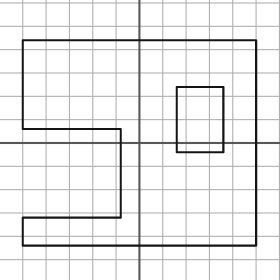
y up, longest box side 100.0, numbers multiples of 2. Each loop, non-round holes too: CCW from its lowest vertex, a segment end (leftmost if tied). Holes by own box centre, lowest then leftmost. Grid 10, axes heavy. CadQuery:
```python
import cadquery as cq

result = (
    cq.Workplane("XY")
    .moveTo(-50.0, -44.0)
    .lineTo(50.0, -44.0)
    .lineTo(50.0, 44.0)
    .lineTo(-50.0, 44.0)
    .lineTo(-50.0, 6.0)
    .lineTo(-8.0, 6.0)
    .lineTo(-8.0, -32.0)
    .lineTo(-50.0, -32.0)
    .close()
    .moveTo(16.0, -4.0)
    .lineTo(36.0, -4.0)
    .lineTo(36.0, 24.0)
    .lineTo(16.0, 24.0)
    .close()
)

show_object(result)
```